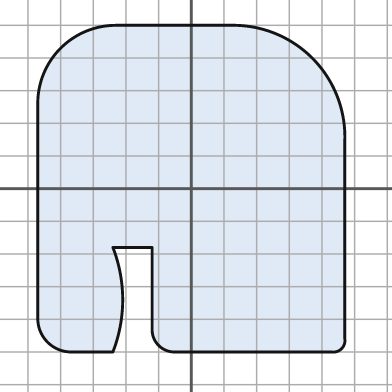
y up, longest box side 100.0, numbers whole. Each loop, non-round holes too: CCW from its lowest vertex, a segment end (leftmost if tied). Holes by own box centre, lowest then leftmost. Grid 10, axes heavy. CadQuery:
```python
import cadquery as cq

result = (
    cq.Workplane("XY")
    .moveTo(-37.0, -50.0)
    .lineTo(-24.0, -50.0)
    .threePointArc((-21.0, -34.0), (-24.0, -18.0))
    .lineTo(-12.0, -18.0)
    .lineTo(-12.0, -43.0)
    .threePointArc((-10.0, -48.0), (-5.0, -50.0))
    .lineTo(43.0, -50.0)
    .threePointArc((46.0, -49.0), (47.0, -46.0))
    .lineTo(47.0, 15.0)
    .threePointArc((37.0, 40.0), (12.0, 50.0))
    .lineTo(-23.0, 50.0)
    .threePointArc((-40.0, 43.0), (-47.0, 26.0))
    .lineTo(-47.0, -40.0)
    .threePointArc((-44.0, -47.0), (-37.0, -50.0))
    .close()
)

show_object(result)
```